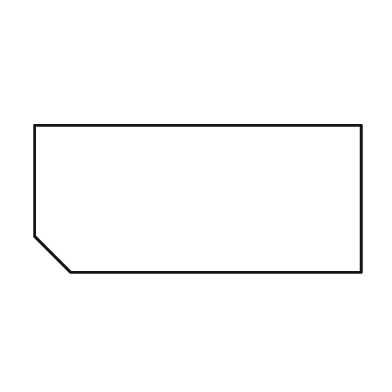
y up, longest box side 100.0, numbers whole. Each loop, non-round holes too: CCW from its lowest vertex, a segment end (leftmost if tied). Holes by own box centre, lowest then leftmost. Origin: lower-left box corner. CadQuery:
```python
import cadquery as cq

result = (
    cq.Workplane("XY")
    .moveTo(11.0, 0.0)
    .lineTo(100.0, 0.0)
    .lineTo(100.0, 45.0)
    .lineTo(0.0, 45.0)
    .lineTo(0.0, 11.0)
    .close()
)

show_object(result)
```